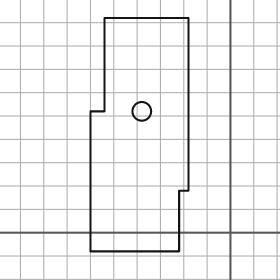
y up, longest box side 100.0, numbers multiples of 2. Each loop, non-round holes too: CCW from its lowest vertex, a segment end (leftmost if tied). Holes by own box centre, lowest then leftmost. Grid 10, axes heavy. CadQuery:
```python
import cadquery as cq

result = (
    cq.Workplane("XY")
    .moveTo(-60.0, -8.0)
    .lineTo(-22.0, -8.0)
    .lineTo(-22.0, 18.0)
    .lineTo(-18.0, 18.0)
    .lineTo(-18.0, 92.0)
    .lineTo(-54.0, 92.0)
    .lineTo(-54.0, 52.0)
    .lineTo(-60.0, 52.0)
    .close()
    .moveTo(-38.0, 52.0)
    .circle(4.0)
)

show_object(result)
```